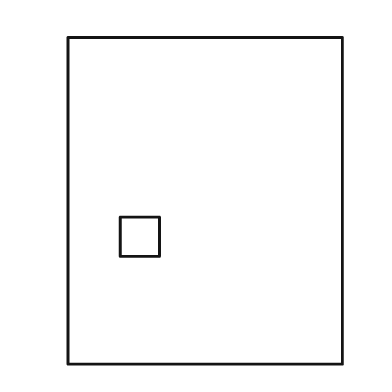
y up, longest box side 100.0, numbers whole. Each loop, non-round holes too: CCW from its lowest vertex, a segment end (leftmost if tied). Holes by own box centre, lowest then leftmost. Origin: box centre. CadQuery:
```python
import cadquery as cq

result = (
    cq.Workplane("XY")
    .moveTo(-42.0, -50.0)
    .lineTo(42.0, -50.0)
    .lineTo(42.0, 50.0)
    .lineTo(-42.0, 50.0)
    .close()
    .moveTo(-26.0, -17.0)
    .lineTo(-14.0, -17.0)
    .lineTo(-14.0, -5.0)
    .lineTo(-26.0, -5.0)
    .close()
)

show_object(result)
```